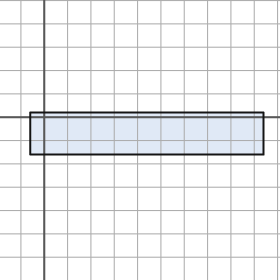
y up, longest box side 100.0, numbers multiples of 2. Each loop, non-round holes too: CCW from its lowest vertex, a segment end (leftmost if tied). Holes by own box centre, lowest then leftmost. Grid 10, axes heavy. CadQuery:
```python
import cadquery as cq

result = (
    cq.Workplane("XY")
    .moveTo(-6.0, -16.0)
    .lineTo(94.0, -16.0)
    .lineTo(94.0, 2.0)
    .lineTo(-6.0, 2.0)
    .close()
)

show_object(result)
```